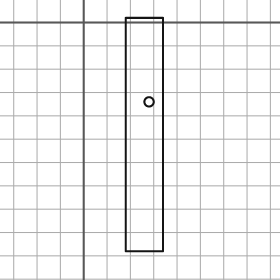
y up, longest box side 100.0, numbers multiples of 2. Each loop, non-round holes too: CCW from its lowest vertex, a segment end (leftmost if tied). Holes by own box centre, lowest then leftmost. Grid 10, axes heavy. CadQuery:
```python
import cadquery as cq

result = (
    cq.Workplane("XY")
    .moveTo(18.0, -98.0)
    .lineTo(34.0, -98.0)
    .lineTo(34.0, 2.0)
    .lineTo(18.0, 2.0)
    .close()
    .moveTo(28.0, -34.0)
    .circle(2.0)
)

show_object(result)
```